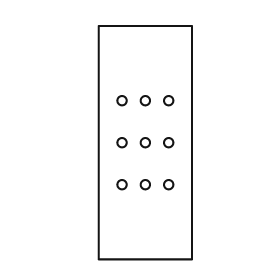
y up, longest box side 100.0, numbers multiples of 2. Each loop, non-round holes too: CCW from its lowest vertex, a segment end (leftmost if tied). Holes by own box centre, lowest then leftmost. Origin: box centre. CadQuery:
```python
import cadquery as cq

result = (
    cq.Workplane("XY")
    .moveTo(-20.0, -50.0)
    .lineTo(20.0, -50.0)
    .lineTo(20.0, 50.0)
    .lineTo(-20.0, 50.0)
    .close()
    .moveTo(-10.0, -18.0)
    .circle(2.0)
    .moveTo(0.0, -18.0)
    .circle(2.0)
    .moveTo(10.0, -18.0)
    .circle(2.0)
    .moveTo(-10.0, 0.0)
    .circle(2.0)
    .moveTo(0.0, 0.0)
    .circle(2.0)
    .moveTo(10.0, 0.0)
    .circle(2.0)
    .moveTo(-10.0, 18.0)
    .circle(2.0)
    .moveTo(0.0, 18.0)
    .circle(2.0)
    .moveTo(10.0, 18.0)
    .circle(2.0)
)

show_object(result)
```